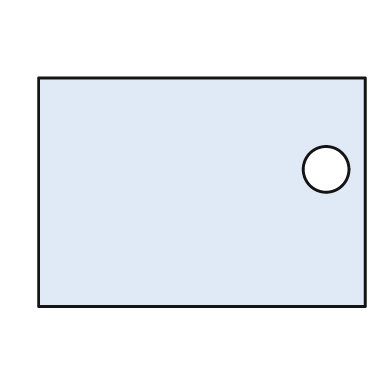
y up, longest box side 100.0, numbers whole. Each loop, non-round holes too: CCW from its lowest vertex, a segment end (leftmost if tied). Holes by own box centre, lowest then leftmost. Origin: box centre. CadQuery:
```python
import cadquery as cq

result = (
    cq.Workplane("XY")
    .moveTo(-50.0, -35.0)
    .lineTo(50.0, -35.0)
    .lineTo(50.0, 35.0)
    .lineTo(-50.0, 35.0)
    .close()
    .moveTo(38.0, 7.0)
    .circle(7.0)
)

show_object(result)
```